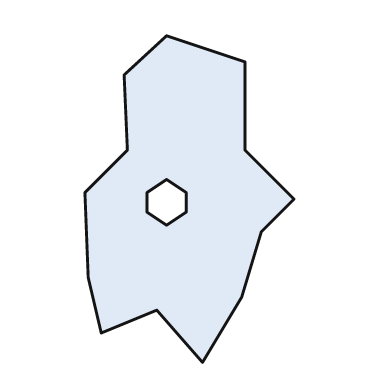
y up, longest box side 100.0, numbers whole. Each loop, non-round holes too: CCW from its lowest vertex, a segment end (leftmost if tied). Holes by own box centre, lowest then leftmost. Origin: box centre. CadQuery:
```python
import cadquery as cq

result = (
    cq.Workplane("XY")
    .moveTo(4.0, -50.0)
    .lineTo(16.0, -30.0)
    .lineTo(22.0, -10.0)
    .lineTo(32.0, 0.0)
    .lineTo(17.0, 15.0)
    .lineTo(17.0, 42.0)
    .lineTo(-7.0, 50.0)
    .lineTo(-20.0, 38.0)
    .lineTo(-19.0, 15.0)
    .lineTo(-32.0, 2.0)
    .lineTo(-31.0, -24.0)
    .lineTo(-27.0, -41.0)
    .lineTo(-10.0, -34.0)
    .close()
    .moveTo(-7.0, -8.0)
    .lineTo(-1.0, -4.0)
    .lineTo(-1.0, 2.0)
    .lineTo(-7.0, 6.0)
    .lineTo(-13.0, 2.0)
    .lineTo(-13.0, -4.0)
    .close()
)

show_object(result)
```